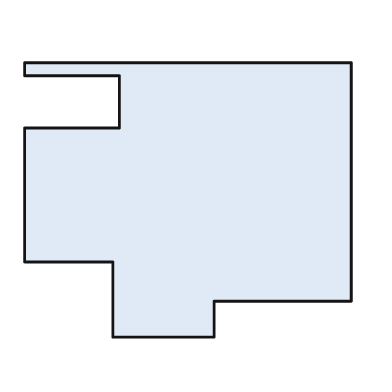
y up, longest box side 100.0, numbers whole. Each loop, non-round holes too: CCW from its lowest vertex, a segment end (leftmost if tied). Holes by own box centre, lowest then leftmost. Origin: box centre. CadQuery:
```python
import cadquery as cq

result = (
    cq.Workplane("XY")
    .moveTo(-23.0, -42.0)
    .lineTo(8.0, -42.0)
    .lineTo(8.0, -31.0)
    .lineTo(50.0, -31.0)
    .lineTo(50.0, 42.0)
    .lineTo(-50.0, 42.0)
    .lineTo(-50.0, 38.0)
    .lineTo(-21.0, 38.0)
    .lineTo(-21.0, 22.0)
    .lineTo(-50.0, 22.0)
    .lineTo(-50.0, -19.0)
    .lineTo(-23.0, -19.0)
    .close()
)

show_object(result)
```